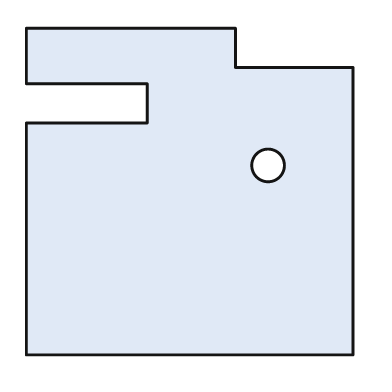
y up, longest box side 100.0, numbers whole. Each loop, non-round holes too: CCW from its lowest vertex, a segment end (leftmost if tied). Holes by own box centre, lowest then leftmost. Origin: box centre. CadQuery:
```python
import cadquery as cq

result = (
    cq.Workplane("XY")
    .moveTo(-50.0, -50.0)
    .lineTo(50.0, -50.0)
    .lineTo(50.0, 38.0)
    .lineTo(14.0, 38.0)
    .lineTo(14.0, 50.0)
    .lineTo(-50.0, 50.0)
    .lineTo(-50.0, 33.0)
    .lineTo(-13.0, 33.0)
    .lineTo(-13.0, 21.0)
    .lineTo(-50.0, 21.0)
    .close()
    .moveTo(24.0, 8.0)
    .circle(5.0)
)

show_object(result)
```